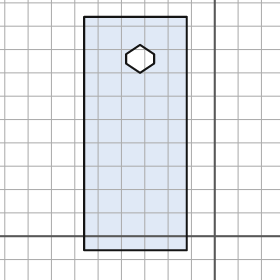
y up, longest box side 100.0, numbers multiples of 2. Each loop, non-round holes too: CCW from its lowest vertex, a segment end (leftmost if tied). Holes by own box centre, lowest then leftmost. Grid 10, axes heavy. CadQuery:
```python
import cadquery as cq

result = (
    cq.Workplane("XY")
    .moveTo(-56.0, -6.0)
    .lineTo(-12.0, -6.0)
    .lineTo(-12.0, 94.0)
    .lineTo(-56.0, 94.0)
    .close()
    .moveTo(-32.0, 70.0)
    .lineTo(-26.0, 74.0)
    .lineTo(-26.0, 78.0)
    .lineTo(-32.0, 82.0)
    .lineTo(-38.0, 78.0)
    .lineTo(-38.0, 74.0)
    .close()
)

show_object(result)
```